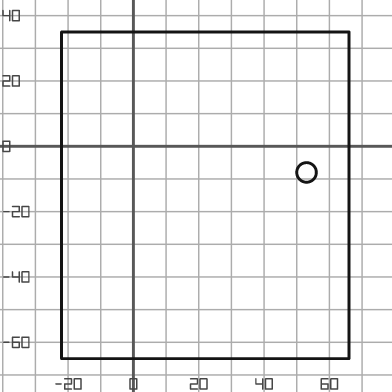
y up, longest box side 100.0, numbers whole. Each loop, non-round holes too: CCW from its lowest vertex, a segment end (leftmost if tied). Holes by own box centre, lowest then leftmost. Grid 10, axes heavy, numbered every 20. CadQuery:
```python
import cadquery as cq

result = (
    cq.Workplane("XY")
    .moveTo(-22.0, -65.0)
    .lineTo(66.0, -65.0)
    .lineTo(66.0, 35.0)
    .lineTo(-22.0, 35.0)
    .close()
    .moveTo(53.0, -8.0)
    .circle(3.0)
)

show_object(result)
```